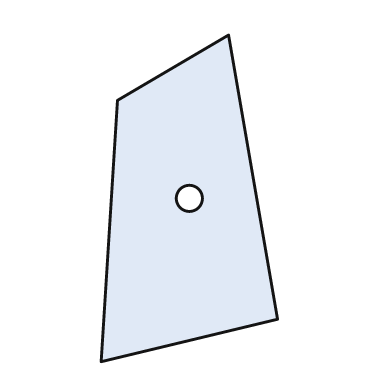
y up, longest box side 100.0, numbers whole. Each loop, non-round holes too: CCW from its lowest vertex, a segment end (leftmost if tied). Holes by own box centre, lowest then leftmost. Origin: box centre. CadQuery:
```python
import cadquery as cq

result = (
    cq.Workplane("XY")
    .moveTo(-27.0, -50.0)
    .lineTo(27.0, -37.0)
    .lineTo(12.0, 50.0)
    .lineTo(-22.0, 30.0)
    .close()
    .moveTo(0.0, 0.0)
    .circle(4.0)
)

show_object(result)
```